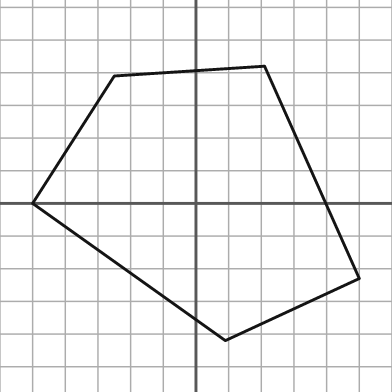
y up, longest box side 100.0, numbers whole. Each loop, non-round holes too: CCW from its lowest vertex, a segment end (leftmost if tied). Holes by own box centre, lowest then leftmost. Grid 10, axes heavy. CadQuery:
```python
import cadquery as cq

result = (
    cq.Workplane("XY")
    .moveTo(9.0, -42.0)
    .lineTo(50.0, -23.0)
    .lineTo(21.0, 42.0)
    .lineTo(-25.0, 39.0)
    .lineTo(-50.0, 0.0)
    .close()
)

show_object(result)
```